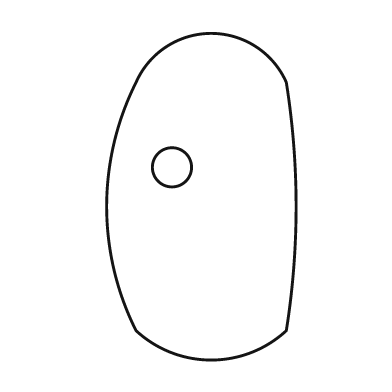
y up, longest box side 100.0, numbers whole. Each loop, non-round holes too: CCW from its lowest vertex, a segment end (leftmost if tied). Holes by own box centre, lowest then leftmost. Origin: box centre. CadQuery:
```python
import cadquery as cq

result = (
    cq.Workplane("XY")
    .moveTo(-20.0, -41.0)
    .threePointArc((3.0, -50.0), (26.0, -41.0))
    .threePointArc((29.0, -3.0), (26.0, 35.0))
    .threePointArc((3.0, 50.0), (-20.0, 35.0))
    .threePointArc((-29.0, -3.0), (-20.0, -41.0))
    .close()
    .moveTo(-9.0, 9.0)
    .circle(6.0)
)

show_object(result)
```